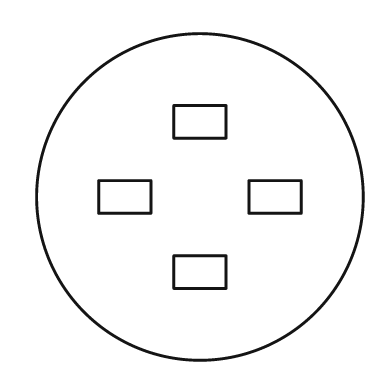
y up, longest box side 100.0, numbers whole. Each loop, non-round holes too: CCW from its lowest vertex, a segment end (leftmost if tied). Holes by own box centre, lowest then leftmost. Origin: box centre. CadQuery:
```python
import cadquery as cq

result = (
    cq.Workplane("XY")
    .moveTo(0.0, 0.0)
    .circle(50.0)
    .moveTo(-8.0, -28.0)
    .lineTo(8.0, -28.0)
    .lineTo(8.0, -18.0)
    .lineTo(-8.0, -18.0)
    .close()
    .moveTo(-31.0, -5.0)
    .lineTo(-15.0, -5.0)
    .lineTo(-15.0, 5.0)
    .lineTo(-31.0, 5.0)
    .close()
    .moveTo(15.0, -5.0)
    .lineTo(31.0, -5.0)
    .lineTo(31.0, 5.0)
    .lineTo(15.0, 5.0)
    .close()
    .moveTo(-8.0, 18.0)
    .lineTo(8.0, 18.0)
    .lineTo(8.0, 28.0)
    .lineTo(-8.0, 28.0)
    .close()
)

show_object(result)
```